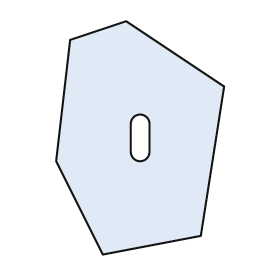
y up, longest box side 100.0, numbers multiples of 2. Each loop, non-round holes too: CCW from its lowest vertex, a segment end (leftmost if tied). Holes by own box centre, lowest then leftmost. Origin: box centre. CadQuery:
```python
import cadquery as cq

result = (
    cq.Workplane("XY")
    .moveTo(-16.0, -50.0)
    .lineTo(26.0, -42.0)
    .lineTo(36.0, 22.0)
    .lineTo(-6.0, 50.0)
    .lineTo(-30.0, 42.0)
    .lineTo(-36.0, -10.0)
    .close()
    .moveTo(-4.0, -6.0)
    .threePointArc((0.0, -10.0), (4.0, -6.0))
    .lineTo(4.0, 6.0)
    .threePointArc((0.0, 10.0), (-4.0, 6.0))
    .close()
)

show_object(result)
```